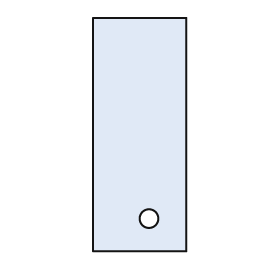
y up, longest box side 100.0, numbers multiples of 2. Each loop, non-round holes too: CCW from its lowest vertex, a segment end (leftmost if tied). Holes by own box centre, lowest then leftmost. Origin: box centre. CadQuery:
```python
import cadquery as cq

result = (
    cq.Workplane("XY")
    .moveTo(-20.0, -50.0)
    .lineTo(20.0, -50.0)
    .lineTo(20.0, 50.0)
    .lineTo(-20.0, 50.0)
    .close()
    .moveTo(4.0, -36.0)
    .circle(4.0)
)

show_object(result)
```